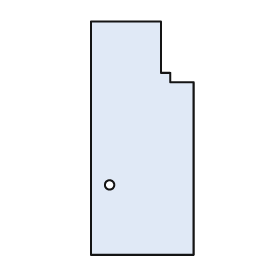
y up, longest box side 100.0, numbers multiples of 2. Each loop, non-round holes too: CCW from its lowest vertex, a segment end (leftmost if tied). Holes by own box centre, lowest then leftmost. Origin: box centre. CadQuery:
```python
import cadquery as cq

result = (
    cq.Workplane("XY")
    .moveTo(-22.0, -50.0)
    .lineTo(22.0, -50.0)
    .lineTo(22.0, 24.0)
    .lineTo(12.0, 24.0)
    .lineTo(12.0, 28.0)
    .lineTo(8.0, 28.0)
    .lineTo(8.0, 50.0)
    .lineTo(-22.0, 50.0)
    .close()
    .moveTo(-14.0, -20.0)
    .circle(2.0)
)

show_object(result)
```